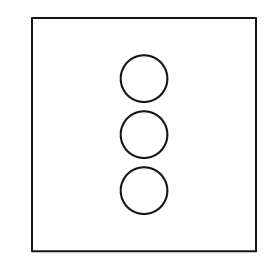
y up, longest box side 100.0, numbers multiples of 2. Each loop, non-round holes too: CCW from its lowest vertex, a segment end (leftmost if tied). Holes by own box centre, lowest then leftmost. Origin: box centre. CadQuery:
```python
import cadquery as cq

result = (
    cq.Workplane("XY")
    .moveTo(-48.0, -50.0)
    .lineTo(48.0, -50.0)
    .lineTo(48.0, 50.0)
    .lineTo(-48.0, 50.0)
    .close()
    .moveTo(0.0, -24.0)
    .circle(10.0)
    .moveTo(0.0, 0.0)
    .circle(10.0)
    .moveTo(0.0, 24.0)
    .circle(10.0)
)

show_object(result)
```